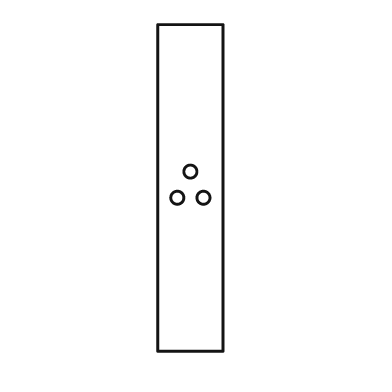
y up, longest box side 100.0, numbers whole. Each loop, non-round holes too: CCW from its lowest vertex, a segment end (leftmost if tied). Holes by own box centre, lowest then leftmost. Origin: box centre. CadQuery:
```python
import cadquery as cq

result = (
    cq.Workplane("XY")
    .moveTo(-10.0, -50.0)
    .lineTo(10.0, -50.0)
    .lineTo(10.0, 50.0)
    .lineTo(-10.0, 50.0)
    .close()
    .moveTo(-4.0, -3.0)
    .circle(2.0)
    .moveTo(4.0, -3.0)
    .circle(2.0)
    .moveTo(0.0, 5.0)
    .circle(2.0)
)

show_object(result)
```